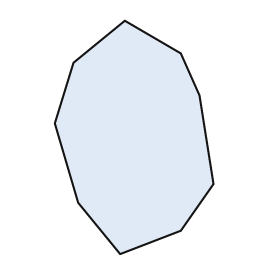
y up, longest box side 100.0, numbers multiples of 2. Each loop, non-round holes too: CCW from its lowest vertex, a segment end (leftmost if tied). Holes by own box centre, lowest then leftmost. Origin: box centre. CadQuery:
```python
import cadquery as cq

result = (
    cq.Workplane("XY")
    .moveTo(-6.0, -50.0)
    .lineTo(20.0, -40.0)
    .lineTo(34.0, -20.0)
    .lineTo(28.0, 18.0)
    .lineTo(20.0, 36.0)
    .lineTo(-4.0, 50.0)
    .lineTo(-26.0, 32.0)
    .lineTo(-34.0, 6.0)
    .lineTo(-24.0, -28.0)
    .close()
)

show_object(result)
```